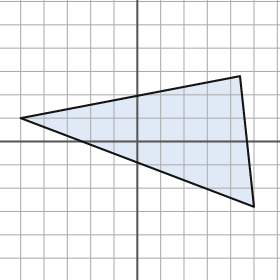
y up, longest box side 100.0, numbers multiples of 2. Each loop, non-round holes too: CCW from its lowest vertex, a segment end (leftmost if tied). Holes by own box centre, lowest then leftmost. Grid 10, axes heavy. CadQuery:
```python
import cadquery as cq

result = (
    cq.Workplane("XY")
    .moveTo(50.0, -28.0)
    .lineTo(44.0, 28.0)
    .lineTo(-50.0, 10.0)
    .close()
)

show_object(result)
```